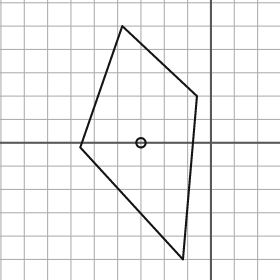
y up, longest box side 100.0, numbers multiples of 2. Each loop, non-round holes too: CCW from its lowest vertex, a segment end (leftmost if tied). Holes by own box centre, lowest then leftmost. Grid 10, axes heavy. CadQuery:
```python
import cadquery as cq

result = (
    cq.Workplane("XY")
    .moveTo(-12.0, -50.0)
    .lineTo(-6.0, 20.0)
    .lineTo(-38.0, 50.0)
    .lineTo(-56.0, -2.0)
    .close()
    .moveTo(-30.0, 0.0)
    .circle(2.0)
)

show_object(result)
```